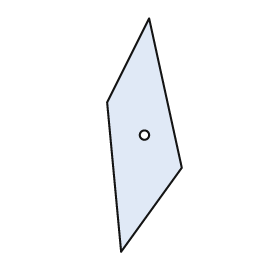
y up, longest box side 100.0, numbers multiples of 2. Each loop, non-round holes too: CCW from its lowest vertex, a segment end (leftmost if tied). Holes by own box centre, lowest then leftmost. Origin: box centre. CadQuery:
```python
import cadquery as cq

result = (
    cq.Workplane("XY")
    .moveTo(-10.0, -50.0)
    .lineTo(16.0, -14.0)
    .lineTo(2.0, 50.0)
    .lineTo(-16.0, 14.0)
    .close()
    .moveTo(0.0, 0.0)
    .circle(2.0)
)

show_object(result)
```